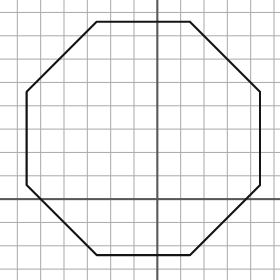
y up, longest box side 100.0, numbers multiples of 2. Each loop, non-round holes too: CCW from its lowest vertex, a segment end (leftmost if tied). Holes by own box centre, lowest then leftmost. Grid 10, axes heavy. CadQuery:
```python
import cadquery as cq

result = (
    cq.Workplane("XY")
    .moveTo(-26.0, -24.0)
    .lineTo(14.0, -24.0)
    .lineTo(44.0, 6.0)
    .lineTo(44.0, 46.0)
    .lineTo(14.0, 76.0)
    .lineTo(-26.0, 76.0)
    .lineTo(-56.0, 46.0)
    .lineTo(-56.0, 6.0)
    .close()
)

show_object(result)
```